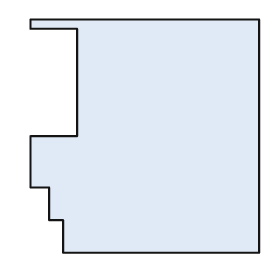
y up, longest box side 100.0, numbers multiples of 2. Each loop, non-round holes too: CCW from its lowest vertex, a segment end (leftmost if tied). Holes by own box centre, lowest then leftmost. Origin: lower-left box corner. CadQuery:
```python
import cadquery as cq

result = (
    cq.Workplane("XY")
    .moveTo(14.0, 0.0)
    .lineTo(98.0, 0.0)
    .lineTo(98.0, 100.0)
    .lineTo(0.0, 100.0)
    .lineTo(0.0, 96.0)
    .lineTo(20.0, 96.0)
    .lineTo(20.0, 50.0)
    .lineTo(0.0, 50.0)
    .lineTo(0.0, 28.0)
    .lineTo(8.0, 28.0)
    .lineTo(8.0, 14.0)
    .lineTo(14.0, 14.0)
    .close()
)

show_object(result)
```